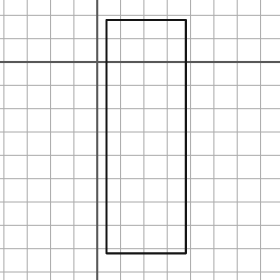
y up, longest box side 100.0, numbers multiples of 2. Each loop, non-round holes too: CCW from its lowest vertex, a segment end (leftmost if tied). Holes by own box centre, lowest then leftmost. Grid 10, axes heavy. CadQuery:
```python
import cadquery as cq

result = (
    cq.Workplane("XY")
    .moveTo(4.0, -82.0)
    .lineTo(38.0, -82.0)
    .lineTo(38.0, 18.0)
    .lineTo(4.0, 18.0)
    .close()
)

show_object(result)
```